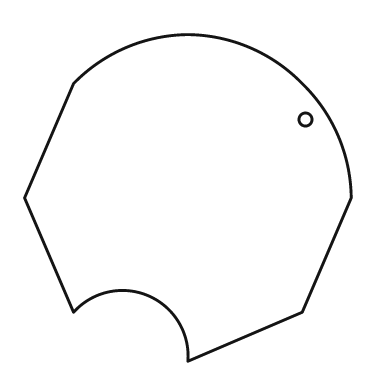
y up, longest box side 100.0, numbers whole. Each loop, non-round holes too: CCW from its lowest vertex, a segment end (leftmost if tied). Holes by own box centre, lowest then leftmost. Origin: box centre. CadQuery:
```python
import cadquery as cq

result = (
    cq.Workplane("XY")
    .moveTo(0.0, -50.0)
    .lineTo(35.0, -35.0)
    .lineTo(50.0, 0.0)
    .threePointArc((46.0, 19.0), (35.0, 35.0))
    .threePointArc((19.0, 46.0), (0.0, 50.0))
    .threePointArc((-19.0, 46.0), (-35.0, 35.0))
    .lineTo(-50.0, 0.0)
    .lineTo(-35.0, -35.0)
    .threePointArc((-12.0, -30.0), (0.0, -50.0))
    .close()
    .moveTo(36.0, 24.0)
    .circle(2.0)
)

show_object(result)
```